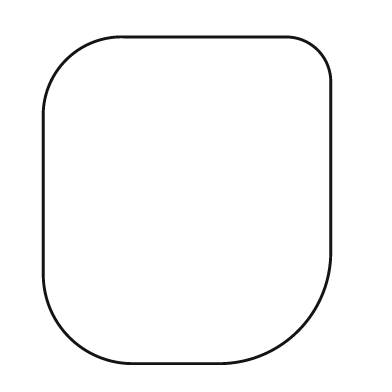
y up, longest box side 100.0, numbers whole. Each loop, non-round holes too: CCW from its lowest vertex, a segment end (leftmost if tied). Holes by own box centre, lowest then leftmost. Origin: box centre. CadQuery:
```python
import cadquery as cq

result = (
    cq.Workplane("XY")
    .moveTo(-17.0, -50.0)
    .lineTo(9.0, -50.0)
    .threePointArc((34.0, -40.0), (44.0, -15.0))
    .lineTo(44.0, 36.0)
    .threePointArc((40.0, 46.0), (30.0, 50.0))
    .lineTo(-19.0, 50.0)
    .threePointArc((-37.0, 43.0), (-44.0, 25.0))
    .lineTo(-44.0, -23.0)
    .threePointArc((-36.0, -42.0), (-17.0, -50.0))
    .close()
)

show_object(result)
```